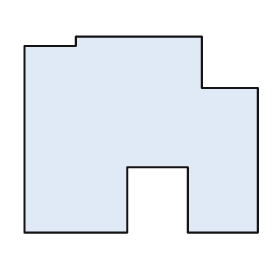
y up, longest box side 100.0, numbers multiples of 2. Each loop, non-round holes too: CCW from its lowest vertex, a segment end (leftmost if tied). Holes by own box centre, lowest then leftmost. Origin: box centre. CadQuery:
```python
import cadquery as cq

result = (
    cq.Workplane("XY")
    .moveTo(-50.0, -42.0)
    .lineTo(-6.0, -42.0)
    .lineTo(-6.0, -14.0)
    .lineTo(20.0, -14.0)
    .lineTo(20.0, -42.0)
    .lineTo(50.0, -42.0)
    .lineTo(50.0, 20.0)
    .lineTo(26.0, 20.0)
    .lineTo(26.0, 42.0)
    .lineTo(-28.0, 42.0)
    .lineTo(-28.0, 38.0)
    .lineTo(-50.0, 38.0)
    .close()
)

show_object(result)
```